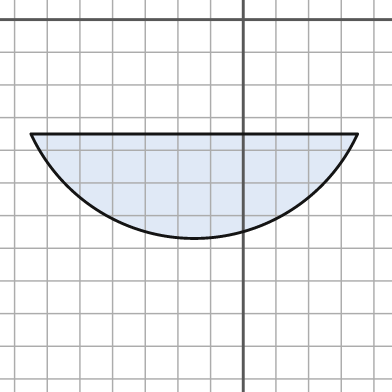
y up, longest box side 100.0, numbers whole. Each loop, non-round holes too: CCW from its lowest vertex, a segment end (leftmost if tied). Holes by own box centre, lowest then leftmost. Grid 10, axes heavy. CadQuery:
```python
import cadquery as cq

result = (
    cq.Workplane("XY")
    .moveTo(-65.0, -35.0)
    .threePointArc((-15.0, -67.0), (35.0, -35.0))
    .close()
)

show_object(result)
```